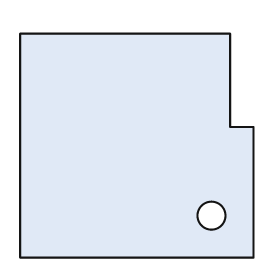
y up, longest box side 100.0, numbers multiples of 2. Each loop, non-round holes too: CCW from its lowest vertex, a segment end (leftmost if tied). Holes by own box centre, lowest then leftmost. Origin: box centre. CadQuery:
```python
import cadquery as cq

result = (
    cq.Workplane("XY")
    .moveTo(-50.0, -48.0)
    .lineTo(50.0, -48.0)
    .lineTo(50.0, 8.0)
    .lineTo(40.0, 8.0)
    .lineTo(40.0, 48.0)
    .lineTo(-50.0, 48.0)
    .close()
    .moveTo(32.0, -30.0)
    .circle(6.0)
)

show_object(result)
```